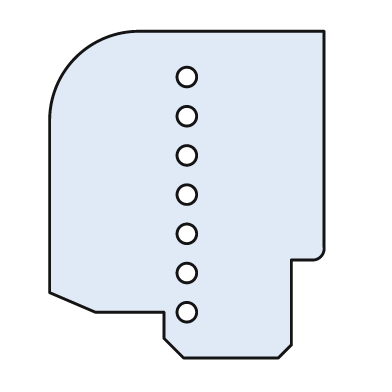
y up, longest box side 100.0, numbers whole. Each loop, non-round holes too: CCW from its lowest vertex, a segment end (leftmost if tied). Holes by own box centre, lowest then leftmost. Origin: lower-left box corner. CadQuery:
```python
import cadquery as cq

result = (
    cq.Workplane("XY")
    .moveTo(41.0, 0.0)
    .lineTo(70.0, 0.0)
    .lineTo(74.0, 4.0)
    .lineTo(74.0, 30.0)
    .lineTo(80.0, 30.0)
    .threePointArc((83.0, 31.0), (84.0, 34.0))
    .lineTo(84.0, 100.0)
    .lineTo(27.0, 100.0)
    .threePointArc((8.0, 92.0), (0.0, 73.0))
    .lineTo(0.0, 20.0)
    .lineTo(14.0, 14.0)
    .lineTo(35.0, 14.0)
    .lineTo(35.0, 6.0)
    .close()
    .moveTo(42.0, 14.0)
    .circle(3.0)
    .moveTo(42.0, 26.0)
    .circle(3.0)
    .moveTo(42.0, 38.0)
    .circle(3.0)
    .moveTo(42.0, 50.0)
    .circle(3.0)
    .moveTo(42.0, 62.0)
    .circle(3.0)
    .moveTo(42.0, 74.0)
    .circle(3.0)
    .moveTo(42.0, 86.0)
    .circle(3.0)
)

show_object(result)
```